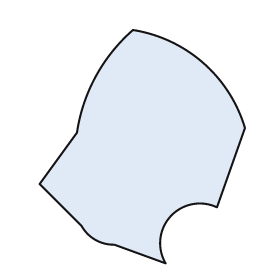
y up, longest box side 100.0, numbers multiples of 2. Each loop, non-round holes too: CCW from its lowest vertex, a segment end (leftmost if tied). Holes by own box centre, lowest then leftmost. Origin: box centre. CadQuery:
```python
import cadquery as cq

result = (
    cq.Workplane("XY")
    .moveTo(10.0, -50.0)
    .threePointArc((12.0, -30.0), (32.0, -26.0))
    .lineTo(44.0, 8.0)
    .threePointArc((26.0, 36.0), (-4.0, 50.0))
    .threePointArc((-20.0, 30.0), (-28.0, 6.0))
    .lineTo(-44.0, -16.0)
    .lineTo(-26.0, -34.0)
    .threePointArc((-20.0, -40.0), (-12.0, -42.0))
    .close()
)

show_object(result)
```